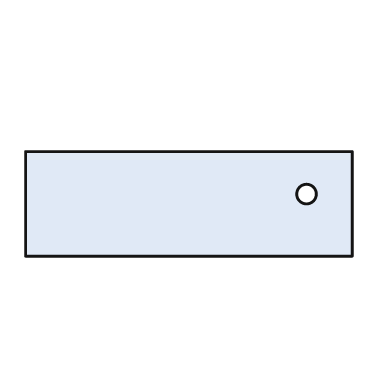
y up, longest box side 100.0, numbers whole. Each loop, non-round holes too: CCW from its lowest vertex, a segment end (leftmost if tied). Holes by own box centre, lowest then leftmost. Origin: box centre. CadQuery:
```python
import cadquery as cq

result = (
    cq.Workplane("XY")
    .moveTo(-50.0, -16.0)
    .lineTo(50.0, -16.0)
    .lineTo(50.0, 16.0)
    .lineTo(-50.0, 16.0)
    .close()
    .moveTo(36.0, 3.0)
    .circle(3.0)
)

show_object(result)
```